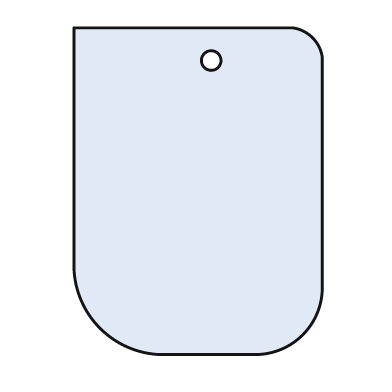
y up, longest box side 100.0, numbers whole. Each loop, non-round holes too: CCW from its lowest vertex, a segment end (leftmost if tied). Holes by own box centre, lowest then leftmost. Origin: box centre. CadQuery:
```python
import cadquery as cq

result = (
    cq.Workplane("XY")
    .moveTo(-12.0, -50.0)
    .lineTo(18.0, -50.0)
    .threePointArc((32.0, -44.0), (38.0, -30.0))
    .lineTo(38.0, 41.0)
    .threePointArc((35.0, 47.0), (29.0, 50.0))
    .lineTo(-38.0, 50.0)
    .lineTo(-38.0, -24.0)
    .threePointArc((-30.0, -42.0), (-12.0, -50.0))
    .close()
    .moveTo(4.0, 40.0)
    .circle(3.0)
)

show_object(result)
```